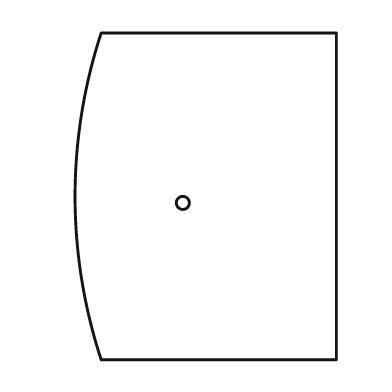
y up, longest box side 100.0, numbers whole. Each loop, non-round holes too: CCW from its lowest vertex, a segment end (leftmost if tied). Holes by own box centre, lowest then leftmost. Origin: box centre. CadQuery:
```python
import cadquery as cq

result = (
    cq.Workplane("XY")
    .moveTo(-32.0, -50.0)
    .lineTo(40.0, -50.0)
    .lineTo(40.0, 50.0)
    .lineTo(-32.0, 50.0)
    .threePointArc((-40.0, 0.0), (-32.0, -50.0))
    .close()
    .moveTo(-7.0, -2.0)
    .circle(2.0)
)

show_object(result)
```